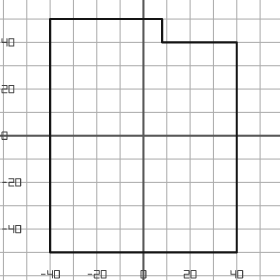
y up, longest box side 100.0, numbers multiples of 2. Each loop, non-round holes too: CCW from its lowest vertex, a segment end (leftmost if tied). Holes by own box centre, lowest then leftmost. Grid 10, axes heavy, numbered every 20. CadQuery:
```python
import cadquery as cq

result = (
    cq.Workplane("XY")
    .moveTo(-40.0, -50.0)
    .lineTo(40.0, -50.0)
    .lineTo(40.0, 40.0)
    .lineTo(8.0, 40.0)
    .lineTo(8.0, 50.0)
    .lineTo(-40.0, 50.0)
    .close()
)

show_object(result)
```